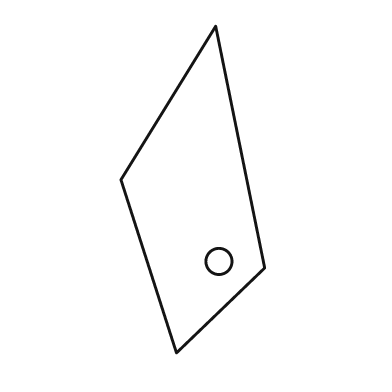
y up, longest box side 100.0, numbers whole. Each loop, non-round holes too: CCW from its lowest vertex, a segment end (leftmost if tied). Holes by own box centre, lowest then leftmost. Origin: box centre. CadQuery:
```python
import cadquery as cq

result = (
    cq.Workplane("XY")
    .moveTo(-5.0, -50.0)
    .lineTo(22.0, -24.0)
    .lineTo(7.0, 50.0)
    .lineTo(-22.0, 3.0)
    .close()
    .moveTo(8.0, -22.0)
    .circle(4.0)
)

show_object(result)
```